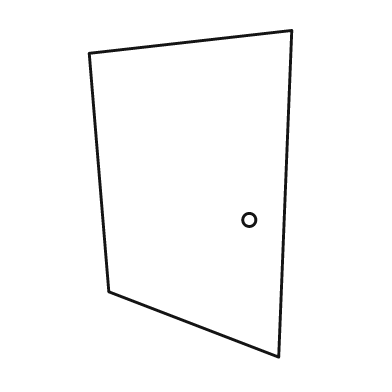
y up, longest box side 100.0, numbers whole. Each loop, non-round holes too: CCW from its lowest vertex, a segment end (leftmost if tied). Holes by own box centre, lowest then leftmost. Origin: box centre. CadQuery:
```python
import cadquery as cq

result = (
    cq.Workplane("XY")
    .moveTo(27.0, -50.0)
    .lineTo(31.0, 50.0)
    .lineTo(-31.0, 43.0)
    .lineTo(-25.0, -30.0)
    .close()
    .moveTo(18.0, -8.0)
    .circle(2.0)
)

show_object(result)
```